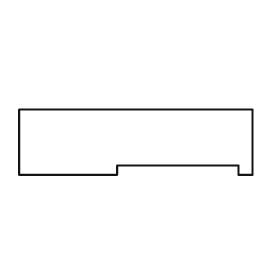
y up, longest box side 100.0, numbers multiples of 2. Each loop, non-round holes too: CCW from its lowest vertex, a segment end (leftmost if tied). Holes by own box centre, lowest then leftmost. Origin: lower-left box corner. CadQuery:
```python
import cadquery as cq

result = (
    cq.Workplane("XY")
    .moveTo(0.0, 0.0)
    .lineTo(42.0, 0.0)
    .lineTo(42.0, 4.0)
    .lineTo(94.0, 4.0)
    .lineTo(94.0, 0.0)
    .lineTo(100.0, 0.0)
    .lineTo(100.0, 28.0)
    .lineTo(0.0, 28.0)
    .close()
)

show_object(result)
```